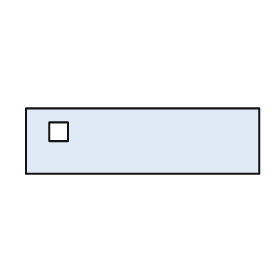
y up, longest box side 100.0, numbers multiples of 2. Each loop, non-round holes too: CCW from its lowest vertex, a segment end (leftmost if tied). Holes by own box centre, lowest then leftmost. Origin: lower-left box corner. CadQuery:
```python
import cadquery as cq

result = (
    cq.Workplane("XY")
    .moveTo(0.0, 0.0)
    .lineTo(100.0, 0.0)
    .lineTo(100.0, 28.0)
    .lineTo(0.0, 28.0)
    .close()
    .moveTo(10.0, 14.0)
    .lineTo(18.0, 14.0)
    .lineTo(18.0, 22.0)
    .lineTo(10.0, 22.0)
    .close()
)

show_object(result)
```